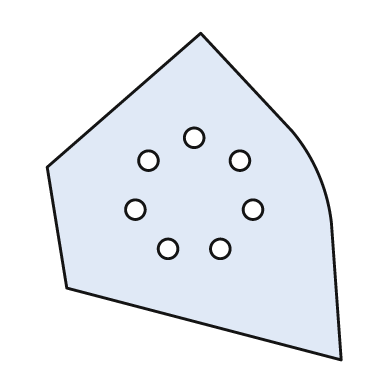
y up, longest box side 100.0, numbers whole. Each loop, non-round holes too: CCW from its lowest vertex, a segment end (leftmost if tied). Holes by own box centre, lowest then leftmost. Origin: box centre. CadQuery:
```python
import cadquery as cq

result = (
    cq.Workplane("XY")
    .moveTo(45.0, -50.0)
    .lineTo(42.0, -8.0)
    .threePointArc((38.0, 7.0), (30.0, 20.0))
    .lineTo(2.0, 50.0)
    .lineTo(-45.0, 9.0)
    .lineTo(-39.0, -28.0)
    .close()
    .moveTo(-8.0, -16.0)
    .circle(3.0)
    .moveTo(8.0, -16.0)
    .circle(3.0)
    .moveTo(-18.0, -4.0)
    .circle(3.0)
    .moveTo(18.0, -4.0)
    .circle(3.0)
    .moveTo(-14.0, 11.0)
    .circle(3.0)
    .moveTo(14.0, 11.0)
    .circle(3.0)
    .moveTo(0.0, 18.0)
    .circle(3.0)
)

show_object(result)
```